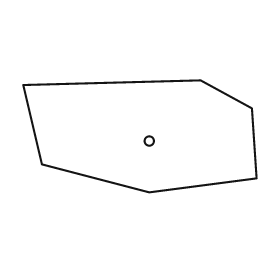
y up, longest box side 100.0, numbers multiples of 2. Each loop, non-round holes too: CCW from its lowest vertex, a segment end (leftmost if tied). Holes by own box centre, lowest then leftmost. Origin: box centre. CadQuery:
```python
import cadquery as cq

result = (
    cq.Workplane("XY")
    .moveTo(4.0, -24.0)
    .lineTo(50.0, -18.0)
    .lineTo(48.0, 12.0)
    .lineTo(26.0, 24.0)
    .lineTo(-50.0, 22.0)
    .lineTo(-42.0, -12.0)
    .close()
    .moveTo(4.0, -2.0)
    .circle(2.0)
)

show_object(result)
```